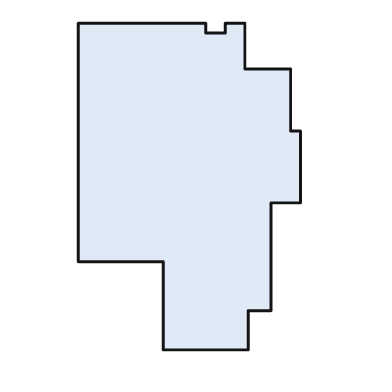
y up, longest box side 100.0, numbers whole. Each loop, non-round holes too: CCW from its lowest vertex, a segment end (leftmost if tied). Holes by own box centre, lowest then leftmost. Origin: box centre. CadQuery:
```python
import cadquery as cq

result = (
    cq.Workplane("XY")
    .moveTo(-8.0, -50.0)
    .lineTo(18.0, -50.0)
    .lineTo(18.0, -38.0)
    .lineTo(25.0, -38.0)
    .lineTo(25.0, -5.0)
    .lineTo(34.0, -5.0)
    .lineTo(34.0, 17.0)
    .lineTo(31.0, 17.0)
    .lineTo(31.0, 36.0)
    .lineTo(17.0, 36.0)
    .lineTo(17.0, 50.0)
    .lineTo(11.0, 50.0)
    .lineTo(11.0, 47.0)
    .lineTo(5.0, 47.0)
    .lineTo(5.0, 50.0)
    .lineTo(-34.0, 50.0)
    .lineTo(-34.0, -23.0)
    .lineTo(-8.0, -23.0)
    .close()
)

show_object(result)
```